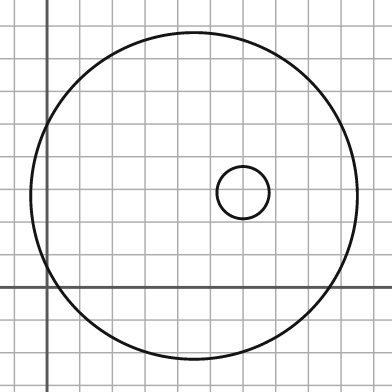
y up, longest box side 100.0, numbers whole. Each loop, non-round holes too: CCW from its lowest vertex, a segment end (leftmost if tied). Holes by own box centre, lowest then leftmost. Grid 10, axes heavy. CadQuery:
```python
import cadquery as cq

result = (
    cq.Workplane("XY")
    .moveTo(45.0, 28.0)
    .circle(50.0)
    .moveTo(60.0, 29.0)
    .circle(8.0)
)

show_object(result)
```